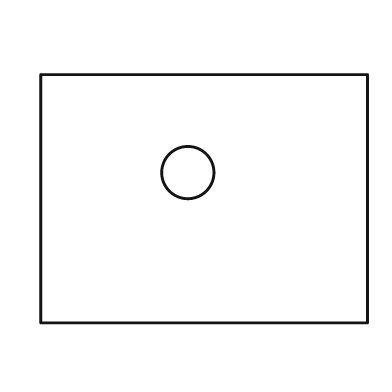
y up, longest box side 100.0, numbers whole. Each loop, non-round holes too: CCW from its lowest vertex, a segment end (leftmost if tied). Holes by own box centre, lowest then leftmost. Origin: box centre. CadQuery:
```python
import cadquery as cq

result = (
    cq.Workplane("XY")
    .moveTo(-50.0, -38.0)
    .lineTo(50.0, -38.0)
    .lineTo(50.0, 38.0)
    .lineTo(-50.0, 38.0)
    .close()
    .moveTo(-5.0, 8.0)
    .circle(8.0)
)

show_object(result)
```